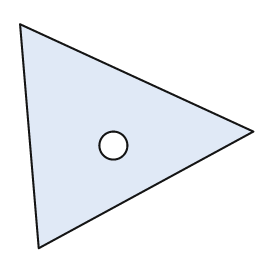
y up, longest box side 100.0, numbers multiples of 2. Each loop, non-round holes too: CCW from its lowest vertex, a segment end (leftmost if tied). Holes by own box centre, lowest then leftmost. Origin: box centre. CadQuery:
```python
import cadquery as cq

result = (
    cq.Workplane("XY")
    .moveTo(-42.0, -48.0)
    .lineTo(50.0, 2.0)
    .lineTo(-50.0, 48.0)
    .close()
    .moveTo(-10.0, -4.0)
    .circle(6.0)
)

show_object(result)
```